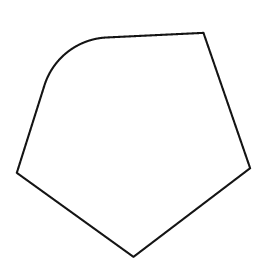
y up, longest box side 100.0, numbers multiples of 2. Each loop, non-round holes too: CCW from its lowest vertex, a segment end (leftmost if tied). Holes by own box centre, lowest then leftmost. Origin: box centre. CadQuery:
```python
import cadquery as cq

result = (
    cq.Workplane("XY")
    .moveTo(0.0, -48.0)
    .lineTo(50.0, -10.0)
    .lineTo(30.0, 48.0)
    .lineTo(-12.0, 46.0)
    .threePointArc((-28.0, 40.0), (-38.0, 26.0))
    .lineTo(-50.0, -12.0)
    .close()
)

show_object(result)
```